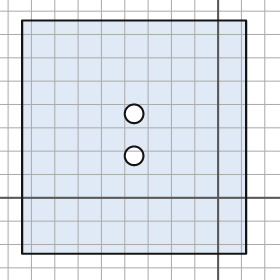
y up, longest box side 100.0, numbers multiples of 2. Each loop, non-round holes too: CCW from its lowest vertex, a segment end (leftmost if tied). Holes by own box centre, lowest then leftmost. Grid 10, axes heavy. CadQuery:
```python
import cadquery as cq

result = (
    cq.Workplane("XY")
    .moveTo(-84.0, -24.0)
    .lineTo(12.0, -24.0)
    .lineTo(12.0, 76.0)
    .lineTo(-84.0, 76.0)
    .close()
    .moveTo(-36.0, 18.0)
    .circle(4.0)
    .moveTo(-36.0, 36.0)
    .circle(4.0)
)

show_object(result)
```